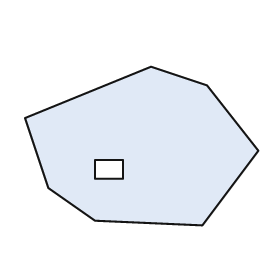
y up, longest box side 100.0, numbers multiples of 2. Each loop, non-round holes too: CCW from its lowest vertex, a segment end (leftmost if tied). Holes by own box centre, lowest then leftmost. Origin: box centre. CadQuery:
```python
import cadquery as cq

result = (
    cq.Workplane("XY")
    .moveTo(26.0, -34.0)
    .lineTo(50.0, -2.0)
    .lineTo(28.0, 26.0)
    .lineTo(4.0, 34.0)
    .lineTo(-50.0, 12.0)
    .lineTo(-40.0, -18.0)
    .lineTo(-20.0, -32.0)
    .close()
    .moveTo(-20.0, -14.0)
    .lineTo(-8.0, -14.0)
    .lineTo(-8.0, -6.0)
    .lineTo(-20.0, -6.0)
    .close()
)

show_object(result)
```